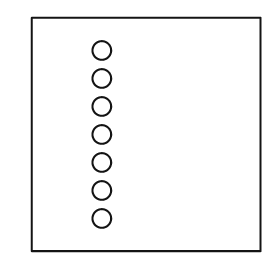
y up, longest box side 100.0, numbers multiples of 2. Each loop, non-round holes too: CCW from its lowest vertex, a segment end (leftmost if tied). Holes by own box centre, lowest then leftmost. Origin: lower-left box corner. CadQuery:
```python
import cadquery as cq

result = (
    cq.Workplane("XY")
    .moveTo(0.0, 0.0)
    .lineTo(98.0, 0.0)
    .lineTo(98.0, 100.0)
    .lineTo(0.0, 100.0)
    .close()
    .moveTo(30.0, 14.0)
    .circle(4.0)
    .moveTo(30.0, 26.0)
    .circle(4.0)
    .moveTo(30.0, 38.0)
    .circle(4.0)
    .moveTo(30.0, 50.0)
    .circle(4.0)
    .moveTo(30.0, 62.0)
    .circle(4.0)
    .moveTo(30.0, 74.0)
    .circle(4.0)
    .moveTo(30.0, 86.0)
    .circle(4.0)
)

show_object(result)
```